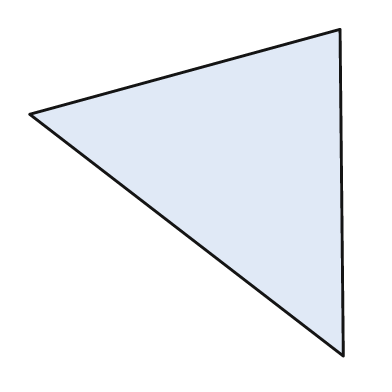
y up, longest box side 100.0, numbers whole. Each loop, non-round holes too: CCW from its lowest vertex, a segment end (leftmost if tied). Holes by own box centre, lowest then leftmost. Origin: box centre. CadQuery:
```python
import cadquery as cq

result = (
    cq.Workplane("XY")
    .moveTo(48.0, -50.0)
    .lineTo(47.0, 50.0)
    .lineTo(-48.0, 24.0)
    .close()
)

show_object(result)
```